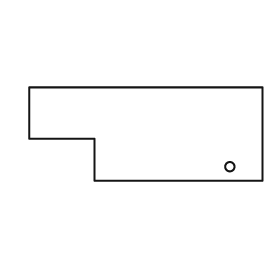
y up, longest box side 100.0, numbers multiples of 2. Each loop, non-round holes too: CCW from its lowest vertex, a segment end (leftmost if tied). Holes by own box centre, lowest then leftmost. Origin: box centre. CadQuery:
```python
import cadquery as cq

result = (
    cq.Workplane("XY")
    .moveTo(-22.0, -20.0)
    .lineTo(50.0, -20.0)
    .lineTo(50.0, 20.0)
    .lineTo(-50.0, 20.0)
    .lineTo(-50.0, -2.0)
    .lineTo(-22.0, -2.0)
    .close()
    .moveTo(36.0, -14.0)
    .circle(2.0)
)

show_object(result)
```